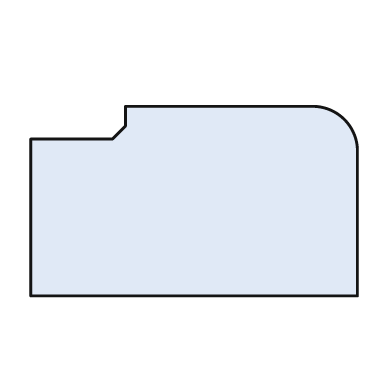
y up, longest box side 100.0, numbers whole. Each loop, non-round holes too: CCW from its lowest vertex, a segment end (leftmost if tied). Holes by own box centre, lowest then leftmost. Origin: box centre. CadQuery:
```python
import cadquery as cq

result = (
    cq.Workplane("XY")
    .moveTo(-50.0, -29.0)
    .lineTo(50.0, -29.0)
    .lineTo(50.0, 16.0)
    .threePointArc((46.0, 25.0), (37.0, 29.0))
    .lineTo(-21.0, 29.0)
    .lineTo(-21.0, 23.0)
    .lineTo(-25.0, 19.0)
    .lineTo(-50.0, 19.0)
    .close()
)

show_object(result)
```